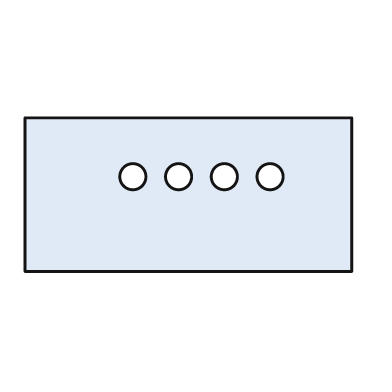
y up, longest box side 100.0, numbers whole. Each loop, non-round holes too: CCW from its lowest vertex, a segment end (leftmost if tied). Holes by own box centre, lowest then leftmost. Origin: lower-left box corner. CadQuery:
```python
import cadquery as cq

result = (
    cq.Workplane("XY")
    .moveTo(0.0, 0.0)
    .lineTo(100.0, 0.0)
    .lineTo(100.0, 47.0)
    .lineTo(0.0, 47.0)
    .close()
    .moveTo(33.0, 29.0)
    .circle(4.0)
    .moveTo(47.0, 29.0)
    .circle(4.0)
    .moveTo(61.0, 29.0)
    .circle(4.0)
    .moveTo(75.0, 29.0)
    .circle(4.0)
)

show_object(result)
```